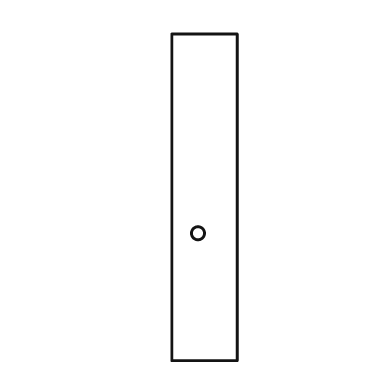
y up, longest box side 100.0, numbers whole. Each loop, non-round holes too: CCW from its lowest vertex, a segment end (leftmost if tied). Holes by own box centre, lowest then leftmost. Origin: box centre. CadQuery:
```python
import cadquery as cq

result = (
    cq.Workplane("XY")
    .moveTo(-10.0, -50.0)
    .lineTo(10.0, -50.0)
    .lineTo(10.0, 50.0)
    .lineTo(-10.0, 50.0)
    .close()
    .moveTo(-2.0, -11.0)
    .circle(2.0)
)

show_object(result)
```